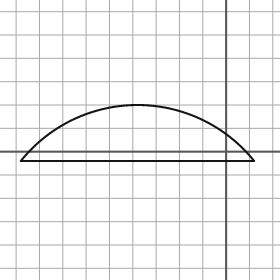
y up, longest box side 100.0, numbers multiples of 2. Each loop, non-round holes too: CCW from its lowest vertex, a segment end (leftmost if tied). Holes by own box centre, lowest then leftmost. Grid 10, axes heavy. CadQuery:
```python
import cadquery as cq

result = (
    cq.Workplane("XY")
    .moveTo(-88.0, -4.0)
    .lineTo(12.0, -4.0)
    .threePointArc((-38.0, 20.0), (-88.0, -4.0))
    .close()
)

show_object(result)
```